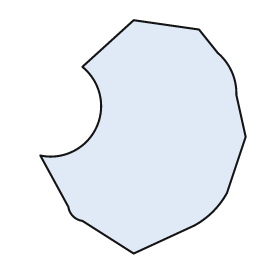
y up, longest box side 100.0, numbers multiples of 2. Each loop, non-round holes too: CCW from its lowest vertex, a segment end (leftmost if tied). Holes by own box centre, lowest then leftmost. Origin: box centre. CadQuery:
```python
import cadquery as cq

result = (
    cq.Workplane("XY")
    .moveTo(-4.0, -50.0)
    .lineTo(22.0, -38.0)
    .threePointArc((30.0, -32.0), (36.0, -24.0))
    .lineTo(44.0, 0.0)
    .lineTo(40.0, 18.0)
    .threePointArc((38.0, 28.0), (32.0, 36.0))
    .lineTo(24.0, 46.0)
    .lineTo(-4.0, 50.0)
    .lineTo(-26.0, 30.0)
    .threePointArc((-20.0, 4.0), (-44.0, -8.0))
    .lineTo(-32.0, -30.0)
    .threePointArc((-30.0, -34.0), (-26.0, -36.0))
    .close()
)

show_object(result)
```